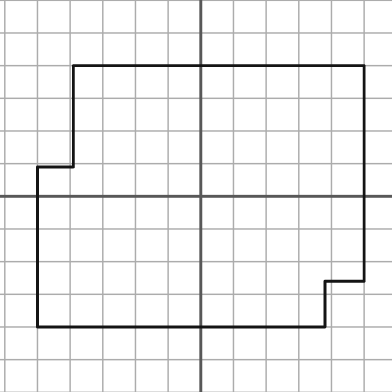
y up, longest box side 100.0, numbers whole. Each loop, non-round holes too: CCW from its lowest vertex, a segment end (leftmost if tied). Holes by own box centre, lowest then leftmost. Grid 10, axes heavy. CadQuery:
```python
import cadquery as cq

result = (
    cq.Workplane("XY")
    .moveTo(-50.0, -40.0)
    .lineTo(38.0, -40.0)
    .lineTo(38.0, -26.0)
    .lineTo(50.0, -26.0)
    .lineTo(50.0, 40.0)
    .lineTo(-39.0, 40.0)
    .lineTo(-39.0, 9.0)
    .lineTo(-50.0, 9.0)
    .close()
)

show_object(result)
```